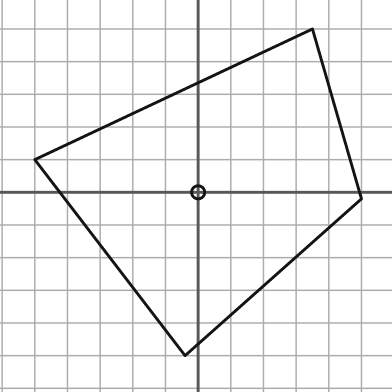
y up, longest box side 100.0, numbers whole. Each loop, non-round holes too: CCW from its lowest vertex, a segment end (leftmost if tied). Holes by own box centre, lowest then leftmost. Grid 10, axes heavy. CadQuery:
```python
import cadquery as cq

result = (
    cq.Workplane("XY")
    .moveTo(-4.0, -50.0)
    .lineTo(50.0, -2.0)
    .lineTo(35.0, 50.0)
    .lineTo(-50.0, 10.0)
    .close()
    .moveTo(0.0, 0.0)
    .circle(2.0)
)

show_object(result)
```